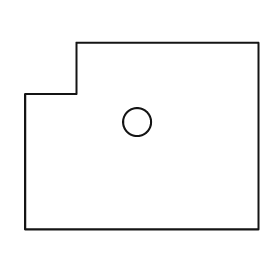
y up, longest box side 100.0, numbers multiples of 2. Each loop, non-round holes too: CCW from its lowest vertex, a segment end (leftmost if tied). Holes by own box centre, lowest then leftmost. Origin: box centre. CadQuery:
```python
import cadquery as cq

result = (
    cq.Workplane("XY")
    .moveTo(-50.0, -40.0)
    .lineTo(50.0, -40.0)
    .lineTo(50.0, 40.0)
    .lineTo(-28.0, 40.0)
    .lineTo(-28.0, 18.0)
    .lineTo(-50.0, 18.0)
    .close()
    .moveTo(-2.0, 6.0)
    .circle(6.0)
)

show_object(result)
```